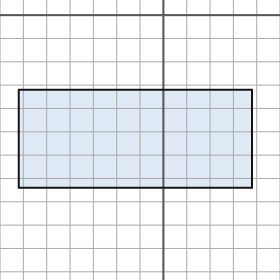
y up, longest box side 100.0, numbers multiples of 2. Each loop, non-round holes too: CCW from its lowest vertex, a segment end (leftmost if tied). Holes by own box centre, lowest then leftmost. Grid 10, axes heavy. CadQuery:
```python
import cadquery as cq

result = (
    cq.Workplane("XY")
    .moveTo(-62.0, -74.0)
    .lineTo(38.0, -74.0)
    .lineTo(38.0, -32.0)
    .lineTo(-62.0, -32.0)
    .close()
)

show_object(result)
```